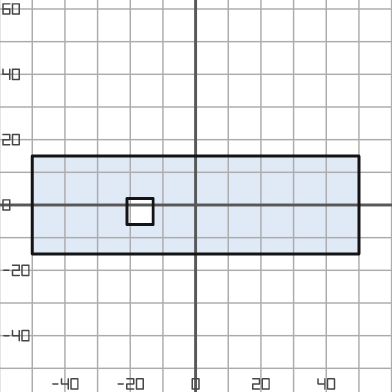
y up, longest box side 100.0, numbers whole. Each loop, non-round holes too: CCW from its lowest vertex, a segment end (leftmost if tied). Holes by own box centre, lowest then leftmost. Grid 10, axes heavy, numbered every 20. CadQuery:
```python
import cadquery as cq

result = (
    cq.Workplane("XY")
    .moveTo(-50.0, -15.0)
    .lineTo(50.0, -15.0)
    .lineTo(50.0, 15.0)
    .lineTo(-50.0, 15.0)
    .close()
    .moveTo(-21.0, -6.0)
    .lineTo(-13.0, -6.0)
    .lineTo(-13.0, 2.0)
    .lineTo(-21.0, 2.0)
    .close()
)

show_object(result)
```